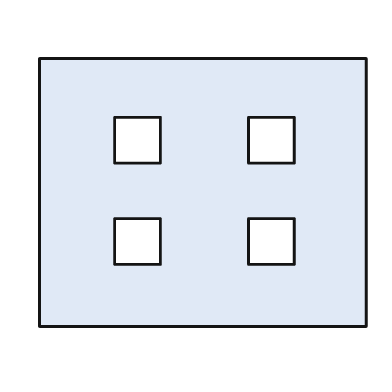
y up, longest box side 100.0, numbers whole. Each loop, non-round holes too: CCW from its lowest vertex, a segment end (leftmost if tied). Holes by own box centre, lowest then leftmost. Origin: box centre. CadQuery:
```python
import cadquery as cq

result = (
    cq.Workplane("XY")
    .moveTo(-50.0, -41.0)
    .lineTo(50.0, -41.0)
    .lineTo(50.0, 41.0)
    .lineTo(-50.0, 41.0)
    .close()
    .moveTo(-27.0, -22.0)
    .lineTo(-13.0, -22.0)
    .lineTo(-13.0, -8.0)
    .lineTo(-27.0, -8.0)
    .close()
    .moveTo(14.0, -22.0)
    .lineTo(28.0, -22.0)
    .lineTo(28.0, -8.0)
    .lineTo(14.0, -8.0)
    .close()
    .moveTo(-27.0, 9.0)
    .lineTo(-13.0, 9.0)
    .lineTo(-13.0, 23.0)
    .lineTo(-27.0, 23.0)
    .close()
    .moveTo(14.0, 9.0)
    .lineTo(28.0, 9.0)
    .lineTo(28.0, 23.0)
    .lineTo(14.0, 23.0)
    .close()
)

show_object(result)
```